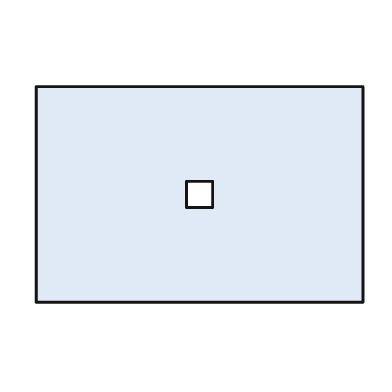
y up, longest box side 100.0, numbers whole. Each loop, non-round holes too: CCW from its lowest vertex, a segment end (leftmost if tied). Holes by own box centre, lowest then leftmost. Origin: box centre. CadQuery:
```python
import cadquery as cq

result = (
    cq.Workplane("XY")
    .moveTo(-50.0, -33.0)
    .lineTo(50.0, -33.0)
    .lineTo(50.0, 33.0)
    .lineTo(-50.0, 33.0)
    .close()
    .moveTo(-4.0, -4.0)
    .lineTo(4.0, -4.0)
    .lineTo(4.0, 4.0)
    .lineTo(-4.0, 4.0)
    .close()
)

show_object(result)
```